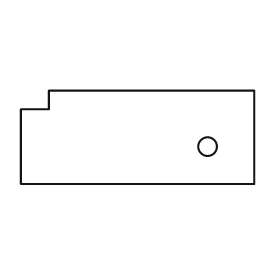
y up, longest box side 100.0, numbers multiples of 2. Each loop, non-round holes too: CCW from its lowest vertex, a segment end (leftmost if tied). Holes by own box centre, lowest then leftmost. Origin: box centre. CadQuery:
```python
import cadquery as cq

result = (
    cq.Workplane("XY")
    .moveTo(-50.0, -20.0)
    .lineTo(50.0, -20.0)
    .lineTo(50.0, 20.0)
    .lineTo(-38.0, 20.0)
    .lineTo(-38.0, 12.0)
    .lineTo(-50.0, 12.0)
    .close()
    .moveTo(30.0, -4.0)
    .circle(4.0)
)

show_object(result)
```